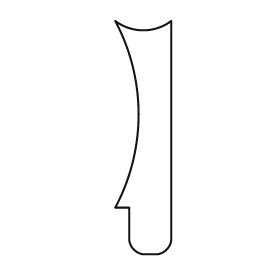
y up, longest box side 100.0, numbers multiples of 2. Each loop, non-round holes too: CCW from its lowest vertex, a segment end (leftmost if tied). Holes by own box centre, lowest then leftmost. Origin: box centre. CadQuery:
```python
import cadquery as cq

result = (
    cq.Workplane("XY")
    .moveTo(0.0, -50.0)
    .lineTo(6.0, -50.0)
    .threePointArc((10.0, -48.0), (12.0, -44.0))
    .lineTo(12.0, 50.0)
    .threePointArc((0.0, 46.0), (-12.0, 50.0))
    .threePointArc((-2.0, 10.0), (-12.0, -30.0))
    .lineTo(-6.0, -30.0)
    .lineTo(-6.0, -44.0)
    .threePointArc((-4.0, -48.0), (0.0, -50.0))
    .close()
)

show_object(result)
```